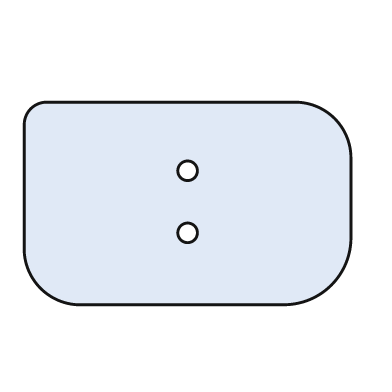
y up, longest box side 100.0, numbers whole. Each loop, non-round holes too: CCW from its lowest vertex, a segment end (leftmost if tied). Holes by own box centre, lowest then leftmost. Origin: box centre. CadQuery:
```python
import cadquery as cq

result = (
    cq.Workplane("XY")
    .moveTo(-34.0, -31.0)
    .lineTo(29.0, -31.0)
    .threePointArc((44.0, -25.0), (50.0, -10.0))
    .lineTo(50.0, 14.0)
    .threePointArc((45.0, 26.0), (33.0, 31.0))
    .lineTo(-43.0, 31.0)
    .threePointArc((-48.0, 29.0), (-50.0, 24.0))
    .lineTo(-50.0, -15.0)
    .threePointArc((-45.0, -26.0), (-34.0, -31.0))
    .close()
    .moveTo(0.0, -9.0)
    .circle(3.0)
    .moveTo(0.0, 10.0)
    .circle(3.0)
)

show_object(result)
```